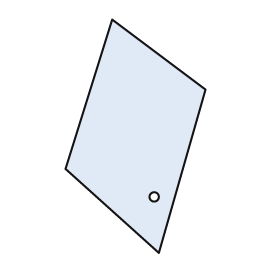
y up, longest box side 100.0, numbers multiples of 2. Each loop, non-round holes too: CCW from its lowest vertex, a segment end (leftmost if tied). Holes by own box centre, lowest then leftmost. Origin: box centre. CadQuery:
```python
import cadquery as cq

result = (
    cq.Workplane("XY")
    .moveTo(10.0, -50.0)
    .lineTo(30.0, 20.0)
    .lineTo(-10.0, 50.0)
    .lineTo(-30.0, -14.0)
    .close()
    .moveTo(8.0, -26.0)
    .circle(2.0)
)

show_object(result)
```